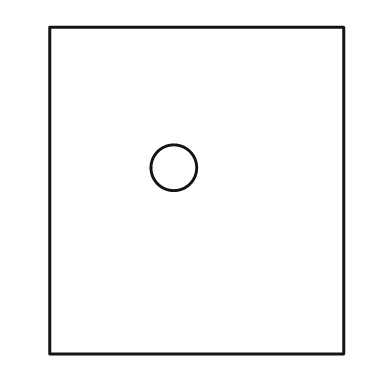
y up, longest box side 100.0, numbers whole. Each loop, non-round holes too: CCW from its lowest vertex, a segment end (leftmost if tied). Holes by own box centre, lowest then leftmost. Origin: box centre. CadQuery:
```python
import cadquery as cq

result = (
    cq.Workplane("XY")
    .moveTo(-45.0, -50.0)
    .lineTo(45.0, -50.0)
    .lineTo(45.0, 50.0)
    .lineTo(-45.0, 50.0)
    .close()
    .moveTo(-7.0, 7.0)
    .circle(7.0)
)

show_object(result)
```